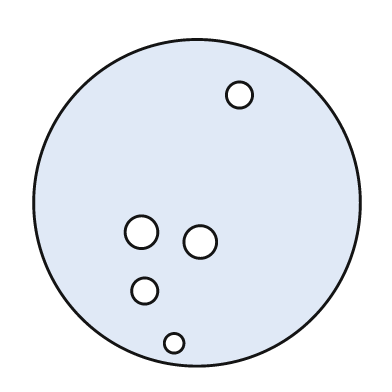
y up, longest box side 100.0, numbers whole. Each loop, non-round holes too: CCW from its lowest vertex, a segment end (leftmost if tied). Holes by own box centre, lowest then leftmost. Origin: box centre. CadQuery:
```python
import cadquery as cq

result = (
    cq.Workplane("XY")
    .moveTo(0.0, 0.0)
    .circle(50.0)
    .moveTo(-7.0, -43.0)
    .circle(3.0)
    .moveTo(-16.0, -27.0)
    .circle(4.0)
    .moveTo(1.0, -12.0)
    .circle(5.0)
    .moveTo(-17.0, -9.0)
    .circle(5.0)
    .moveTo(13.0, 33.0)
    .circle(4.0)
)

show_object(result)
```